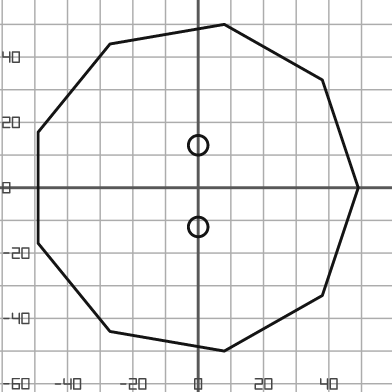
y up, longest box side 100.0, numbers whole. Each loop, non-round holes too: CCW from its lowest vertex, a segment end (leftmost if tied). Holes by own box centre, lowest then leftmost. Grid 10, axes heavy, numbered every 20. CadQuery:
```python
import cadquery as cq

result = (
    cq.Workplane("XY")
    .moveTo(8.0, -50.0)
    .lineTo(38.0, -33.0)
    .lineTo(49.0, 0.0)
    .lineTo(38.0, 33.0)
    .lineTo(8.0, 50.0)
    .lineTo(-27.0, 44.0)
    .lineTo(-49.0, 17.0)
    .lineTo(-49.0, -17.0)
    .lineTo(-27.0, -44.0)
    .close()
    .moveTo(0.0, -12.0)
    .circle(3.0)
    .moveTo(0.0, 13.0)
    .circle(3.0)
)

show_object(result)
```